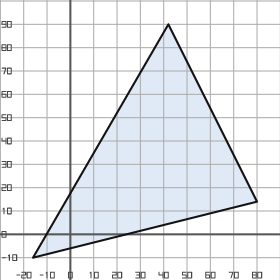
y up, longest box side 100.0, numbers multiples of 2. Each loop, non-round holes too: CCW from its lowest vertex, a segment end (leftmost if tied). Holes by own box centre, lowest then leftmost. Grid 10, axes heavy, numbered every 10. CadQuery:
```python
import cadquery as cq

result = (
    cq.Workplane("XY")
    .moveTo(-16.0, -10.0)
    .lineTo(80.0, 14.0)
    .lineTo(42.0, 90.0)
    .close()
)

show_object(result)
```